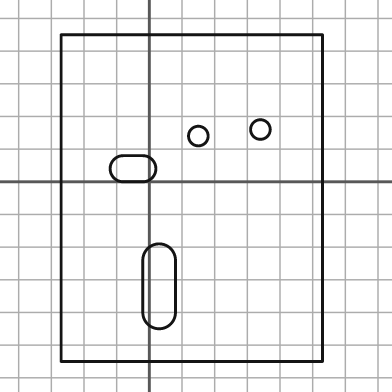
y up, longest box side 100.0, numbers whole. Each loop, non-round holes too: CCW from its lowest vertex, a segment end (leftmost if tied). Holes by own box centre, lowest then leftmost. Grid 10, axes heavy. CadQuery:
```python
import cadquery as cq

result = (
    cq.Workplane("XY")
    .moveTo(-27.0, -55.0)
    .lineTo(53.0, -55.0)
    .lineTo(53.0, 45.0)
    .lineTo(-27.0, 45.0)
    .close()
    .moveTo(-2.0, -40.0)
    .threePointArc((3.0, -45.0), (8.0, -40.0))
    .lineTo(8.0, -24.0)
    .threePointArc((3.0, -19.0), (-2.0, -24.0))
    .close()
    .moveTo(-8.0, 0.0)
    .lineTo(-2.0, 0.0)
    .threePointArc((2.0, 4.0), (-2.0, 8.0))
    .lineTo(-8.0, 8.0)
    .threePointArc((-12.0, 4.0), (-8.0, 0.0))
    .close()
    .moveTo(15.0, 14.0)
    .circle(3.0)
    .moveTo(34.0, 16.0)
    .circle(3.0)
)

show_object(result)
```